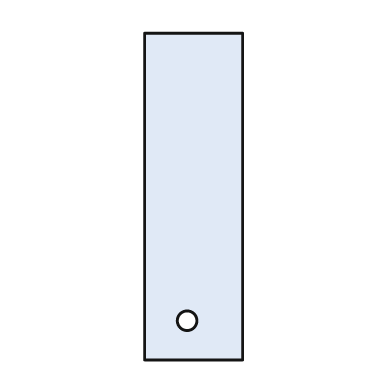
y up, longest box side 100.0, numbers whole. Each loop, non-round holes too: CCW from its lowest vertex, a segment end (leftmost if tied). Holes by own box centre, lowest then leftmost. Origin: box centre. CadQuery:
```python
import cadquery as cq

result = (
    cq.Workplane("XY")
    .moveTo(-15.0, -50.0)
    .lineTo(15.0, -50.0)
    .lineTo(15.0, 50.0)
    .lineTo(-15.0, 50.0)
    .close()
    .moveTo(-2.0, -38.0)
    .circle(3.0)
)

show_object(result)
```